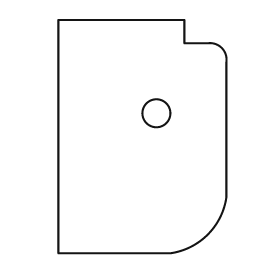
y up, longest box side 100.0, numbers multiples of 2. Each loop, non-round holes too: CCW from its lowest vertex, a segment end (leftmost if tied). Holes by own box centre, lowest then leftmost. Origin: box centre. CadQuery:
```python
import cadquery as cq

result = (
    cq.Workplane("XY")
    .moveTo(-36.0, -50.0)
    .lineTo(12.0, -50.0)
    .threePointArc((28.0, -42.0), (36.0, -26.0))
    .lineTo(36.0, 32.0)
    .threePointArc((34.0, 38.0), (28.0, 40.0))
    .lineTo(18.0, 40.0)
    .lineTo(18.0, 50.0)
    .lineTo(-36.0, 50.0)
    .close()
    .moveTo(6.0, 10.0)
    .circle(6.0)
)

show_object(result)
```